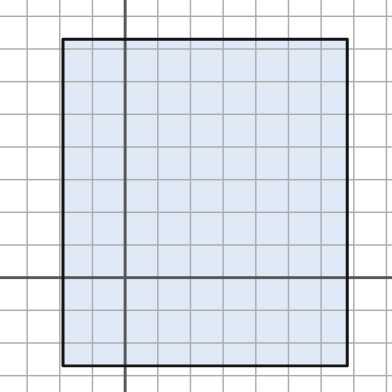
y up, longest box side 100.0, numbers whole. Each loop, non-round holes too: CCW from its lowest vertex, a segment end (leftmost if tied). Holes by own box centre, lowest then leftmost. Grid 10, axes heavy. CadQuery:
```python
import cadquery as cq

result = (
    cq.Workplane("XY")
    .moveTo(-19.0, -27.0)
    .lineTo(68.0, -27.0)
    .lineTo(68.0, 73.0)
    .lineTo(-19.0, 73.0)
    .close()
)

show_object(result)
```